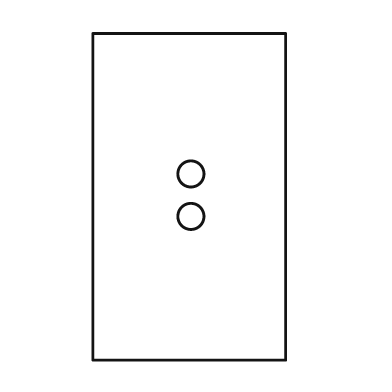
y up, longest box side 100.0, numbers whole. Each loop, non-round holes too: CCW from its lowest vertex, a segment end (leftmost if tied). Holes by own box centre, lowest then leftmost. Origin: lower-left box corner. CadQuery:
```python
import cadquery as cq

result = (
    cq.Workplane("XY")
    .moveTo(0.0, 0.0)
    .lineTo(59.0, 0.0)
    .lineTo(59.0, 100.0)
    .lineTo(0.0, 100.0)
    .close()
    .moveTo(30.0, 44.0)
    .circle(4.0)
    .moveTo(30.0, 57.0)
    .circle(4.0)
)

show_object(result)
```